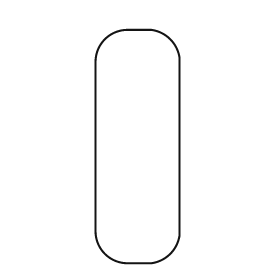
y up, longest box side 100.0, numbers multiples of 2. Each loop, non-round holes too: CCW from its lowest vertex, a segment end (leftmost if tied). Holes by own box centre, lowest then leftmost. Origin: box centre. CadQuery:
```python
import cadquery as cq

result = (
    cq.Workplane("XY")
    .moveTo(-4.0, -50.0)
    .lineTo(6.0, -50.0)
    .threePointArc((14.0, -46.0), (18.0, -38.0))
    .lineTo(18.0, 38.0)
    .threePointArc((14.0, 46.0), (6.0, 50.0))
    .lineTo(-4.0, 50.0)
    .threePointArc((-14.0, 46.0), (-18.0, 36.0))
    .lineTo(-18.0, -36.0)
    .threePointArc((-14.0, -46.0), (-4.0, -50.0))
    .close()
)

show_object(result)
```